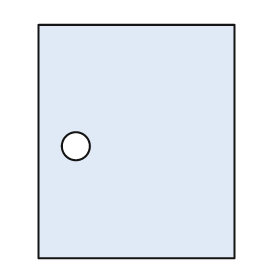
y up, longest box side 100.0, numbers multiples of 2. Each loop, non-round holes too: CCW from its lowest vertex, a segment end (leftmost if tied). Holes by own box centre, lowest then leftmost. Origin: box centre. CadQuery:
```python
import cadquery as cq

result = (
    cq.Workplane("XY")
    .moveTo(-42.0, -50.0)
    .lineTo(42.0, -50.0)
    .lineTo(42.0, 50.0)
    .lineTo(-42.0, 50.0)
    .close()
    .moveTo(-26.0, -2.0)
    .circle(6.0)
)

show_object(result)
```